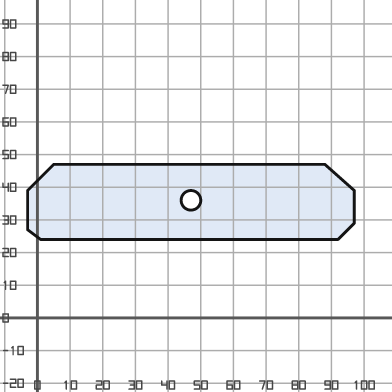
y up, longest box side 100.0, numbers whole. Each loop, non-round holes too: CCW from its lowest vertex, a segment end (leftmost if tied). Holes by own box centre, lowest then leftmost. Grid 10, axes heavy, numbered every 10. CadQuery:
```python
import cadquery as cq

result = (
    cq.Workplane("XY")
    .moveTo(1.0, 24.0)
    .lineTo(92.0, 24.0)
    .lineTo(97.0, 29.0)
    .lineTo(97.0, 39.0)
    .lineTo(88.0, 47.0)
    .lineTo(5.0, 47.0)
    .lineTo(-3.0, 39.0)
    .lineTo(-3.0, 27.0)
    .close()
    .moveTo(47.0, 36.0)
    .circle(3.0)
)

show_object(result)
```